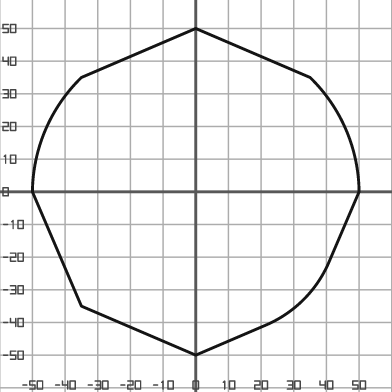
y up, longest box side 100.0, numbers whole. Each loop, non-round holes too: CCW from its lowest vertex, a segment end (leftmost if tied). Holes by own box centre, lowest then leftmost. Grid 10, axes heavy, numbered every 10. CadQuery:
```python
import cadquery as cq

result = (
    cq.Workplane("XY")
    .moveTo(0.0, -50.0)
    .lineTo(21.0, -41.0)
    .threePointArc((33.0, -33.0), (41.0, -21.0))
    .lineTo(50.0, 0.0)
    .threePointArc((46.0, 19.0), (35.0, 35.0))
    .lineTo(0.0, 50.0)
    .lineTo(-35.0, 35.0)
    .threePointArc((-46.0, 19.0), (-50.0, 0.0))
    .lineTo(-35.0, -35.0)
    .close()
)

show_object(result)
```